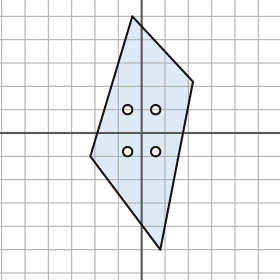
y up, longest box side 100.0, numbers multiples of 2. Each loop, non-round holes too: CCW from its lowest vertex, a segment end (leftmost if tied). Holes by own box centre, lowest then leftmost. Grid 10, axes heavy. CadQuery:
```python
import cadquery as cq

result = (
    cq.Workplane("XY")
    .moveTo(8.0, -50.0)
    .lineTo(22.0, 22.0)
    .lineTo(-4.0, 50.0)
    .lineTo(-22.0, -10.0)
    .close()
    .moveTo(-6.0, -8.0)
    .circle(2.0)
    .moveTo(6.0, -8.0)
    .circle(2.0)
    .moveTo(-6.0, 10.0)
    .circle(2.0)
    .moveTo(6.0, 10.0)
    .circle(2.0)
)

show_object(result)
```